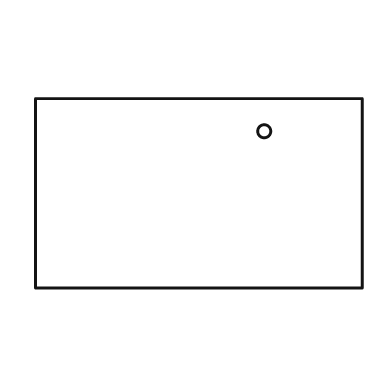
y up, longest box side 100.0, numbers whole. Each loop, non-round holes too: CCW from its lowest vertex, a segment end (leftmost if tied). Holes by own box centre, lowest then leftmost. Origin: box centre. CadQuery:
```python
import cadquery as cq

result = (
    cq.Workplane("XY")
    .moveTo(-50.0, -29.0)
    .lineTo(50.0, -29.0)
    .lineTo(50.0, 29.0)
    .lineTo(-50.0, 29.0)
    .close()
    .moveTo(20.0, 19.0)
    .circle(2.0)
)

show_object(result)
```